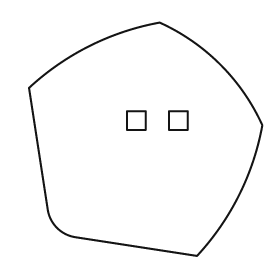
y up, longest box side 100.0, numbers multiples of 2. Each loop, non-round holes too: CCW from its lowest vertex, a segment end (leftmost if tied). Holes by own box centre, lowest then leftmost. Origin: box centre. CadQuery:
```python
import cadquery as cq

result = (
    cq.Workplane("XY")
    .moveTo(22.0, -50.0)
    .threePointArc((40.0, -24.0), (50.0, 6.0))
    .threePointArc((32.0, 32.0), (6.0, 50.0))
    .threePointArc((-24.0, 40.0), (-50.0, 22.0))
    .lineTo(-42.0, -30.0)
    .threePointArc((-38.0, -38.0), (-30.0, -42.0))
    .close()
    .moveTo(-8.0, 4.0)
    .lineTo(0.0, 4.0)
    .lineTo(0.0, 12.0)
    .lineTo(-8.0, 12.0)
    .close()
    .moveTo(10.0, 4.0)
    .lineTo(18.0, 4.0)
    .lineTo(18.0, 12.0)
    .lineTo(10.0, 12.0)
    .close()
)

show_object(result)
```